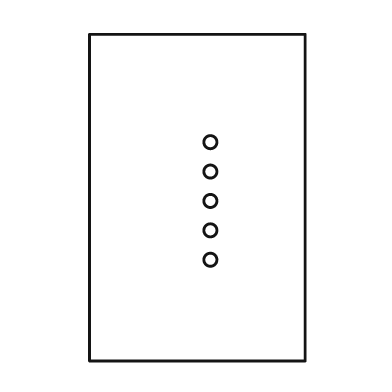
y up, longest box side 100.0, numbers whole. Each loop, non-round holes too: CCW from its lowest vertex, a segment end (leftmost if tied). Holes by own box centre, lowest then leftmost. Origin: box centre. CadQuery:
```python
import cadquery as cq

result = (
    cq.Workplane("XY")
    .moveTo(-33.0, -50.0)
    .lineTo(33.0, -50.0)
    .lineTo(33.0, 50.0)
    .lineTo(-33.0, 50.0)
    .close()
    .moveTo(4.0, -19.0)
    .circle(2.0)
    .moveTo(4.0, -10.0)
    .circle(2.0)
    .moveTo(4.0, -1.0)
    .circle(2.0)
    .moveTo(4.0, 8.0)
    .circle(2.0)
    .moveTo(4.0, 17.0)
    .circle(2.0)
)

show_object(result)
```